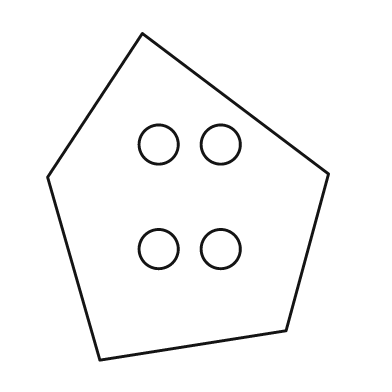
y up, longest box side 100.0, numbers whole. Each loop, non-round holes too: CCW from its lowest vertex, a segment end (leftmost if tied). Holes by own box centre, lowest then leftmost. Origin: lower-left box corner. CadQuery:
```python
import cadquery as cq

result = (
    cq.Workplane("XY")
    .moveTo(16.0, 0.0)
    .lineTo(73.0, 9.0)
    .lineTo(86.0, 57.0)
    .lineTo(29.0, 100.0)
    .lineTo(0.0, 56.0)
    .close()
    .moveTo(34.0, 34.0)
    .circle(6.0)
    .moveTo(53.0, 34.0)
    .circle(6.0)
    .moveTo(34.0, 66.0)
    .circle(6.0)
    .moveTo(53.0, 66.0)
    .circle(6.0)
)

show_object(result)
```